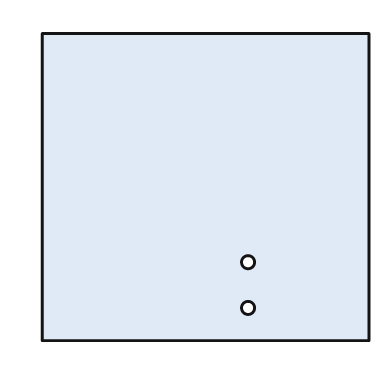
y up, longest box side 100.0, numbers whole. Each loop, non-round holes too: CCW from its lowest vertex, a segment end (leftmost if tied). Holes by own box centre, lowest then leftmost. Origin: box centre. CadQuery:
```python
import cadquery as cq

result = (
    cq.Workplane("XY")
    .moveTo(-50.0, -47.0)
    .lineTo(50.0, -47.0)
    .lineTo(50.0, 47.0)
    .lineTo(-50.0, 47.0)
    .close()
    .moveTo(13.0, -37.0)
    .circle(2.0)
    .moveTo(13.0, -23.0)
    .circle(2.0)
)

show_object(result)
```